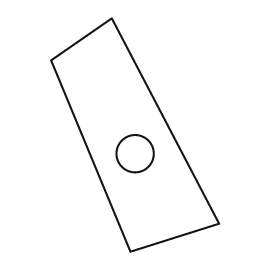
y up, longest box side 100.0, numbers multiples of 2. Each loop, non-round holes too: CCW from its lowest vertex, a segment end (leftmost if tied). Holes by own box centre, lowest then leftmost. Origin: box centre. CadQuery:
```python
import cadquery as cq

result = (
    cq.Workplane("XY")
    .moveTo(-2.0, -50.0)
    .lineTo(36.0, -38.0)
    .lineTo(-10.0, 50.0)
    .lineTo(-36.0, 32.0)
    .close()
    .moveTo(0.0, -8.0)
    .circle(8.0)
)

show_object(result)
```